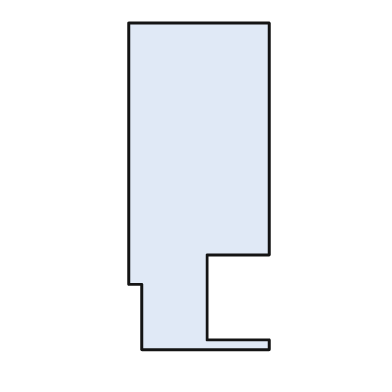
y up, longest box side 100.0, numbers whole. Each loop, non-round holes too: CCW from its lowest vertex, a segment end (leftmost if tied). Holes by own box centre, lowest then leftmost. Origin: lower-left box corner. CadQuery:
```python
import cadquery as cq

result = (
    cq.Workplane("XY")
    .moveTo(4.0, 0.0)
    .lineTo(43.0, 0.0)
    .lineTo(43.0, 3.0)
    .lineTo(24.0, 3.0)
    .lineTo(24.0, 29.0)
    .lineTo(43.0, 29.0)
    .lineTo(43.0, 100.0)
    .lineTo(0.0, 100.0)
    .lineTo(0.0, 20.0)
    .lineTo(4.0, 20.0)
    .close()
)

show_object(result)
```